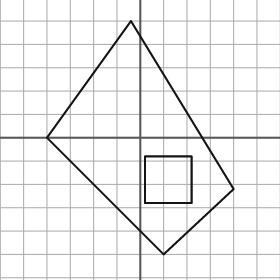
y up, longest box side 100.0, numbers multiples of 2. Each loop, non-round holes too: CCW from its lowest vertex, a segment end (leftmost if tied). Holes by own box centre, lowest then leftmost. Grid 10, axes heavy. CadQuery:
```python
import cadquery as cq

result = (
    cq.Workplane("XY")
    .moveTo(10.0, -50.0)
    .lineTo(40.0, -22.0)
    .lineTo(-4.0, 50.0)
    .lineTo(-40.0, 0.0)
    .close()
    .moveTo(2.0, -28.0)
    .lineTo(22.0, -28.0)
    .lineTo(22.0, -8.0)
    .lineTo(2.0, -8.0)
    .close()
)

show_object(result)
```